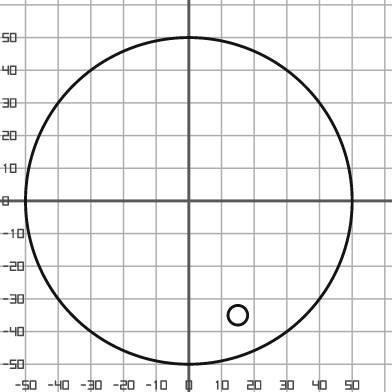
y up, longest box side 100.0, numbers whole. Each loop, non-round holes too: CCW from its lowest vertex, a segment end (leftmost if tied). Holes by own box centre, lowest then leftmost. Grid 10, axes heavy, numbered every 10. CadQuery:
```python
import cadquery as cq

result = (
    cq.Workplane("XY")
    .moveTo(0.0, 0.0)
    .circle(50.0)
    .moveTo(15.0, -35.0)
    .circle(3.0)
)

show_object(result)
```